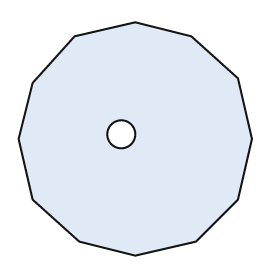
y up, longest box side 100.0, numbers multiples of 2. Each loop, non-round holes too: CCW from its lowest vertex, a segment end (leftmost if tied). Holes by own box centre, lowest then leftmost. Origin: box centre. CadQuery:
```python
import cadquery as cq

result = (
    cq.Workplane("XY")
    .moveTo(0.0, -50.0)
    .lineTo(26.0, -44.0)
    .lineTo(44.0, -26.0)
    .lineTo(50.0, 0.0)
    .lineTo(44.0, 26.0)
    .lineTo(24.0, 44.0)
    .lineTo(0.0, 50.0)
    .lineTo(-26.0, 44.0)
    .lineTo(-44.0, 24.0)
    .lineTo(-50.0, 0.0)
    .lineTo(-44.0, -26.0)
    .lineTo(-24.0, -44.0)
    .close()
    .moveTo(-6.0, 2.0)
    .circle(6.0)
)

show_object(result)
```